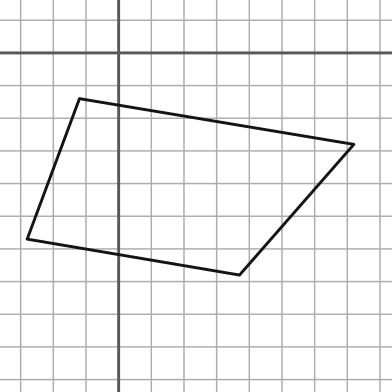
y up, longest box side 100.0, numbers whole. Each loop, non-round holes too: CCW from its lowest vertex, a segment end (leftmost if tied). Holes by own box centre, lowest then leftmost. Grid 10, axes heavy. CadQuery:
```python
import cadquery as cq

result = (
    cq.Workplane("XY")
    .moveTo(37.0, -68.0)
    .lineTo(72.0, -28.0)
    .lineTo(-12.0, -14.0)
    .lineTo(-28.0, -57.0)
    .close()
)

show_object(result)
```